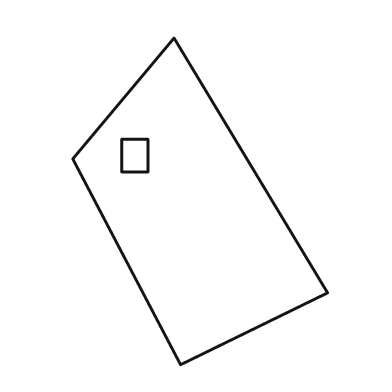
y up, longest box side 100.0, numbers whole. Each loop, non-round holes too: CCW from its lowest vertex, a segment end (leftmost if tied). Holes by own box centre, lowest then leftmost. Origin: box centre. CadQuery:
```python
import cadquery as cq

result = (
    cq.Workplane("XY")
    .moveTo(-6.0, -50.0)
    .lineTo(39.0, -28.0)
    .lineTo(-8.0, 50.0)
    .lineTo(-39.0, 13.0)
    .close()
    .moveTo(-24.0, 9.0)
    .lineTo(-16.0, 9.0)
    .lineTo(-16.0, 19.0)
    .lineTo(-24.0, 19.0)
    .close()
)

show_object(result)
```